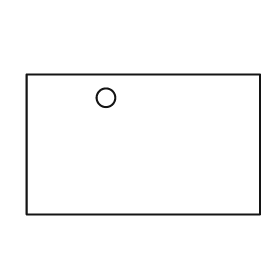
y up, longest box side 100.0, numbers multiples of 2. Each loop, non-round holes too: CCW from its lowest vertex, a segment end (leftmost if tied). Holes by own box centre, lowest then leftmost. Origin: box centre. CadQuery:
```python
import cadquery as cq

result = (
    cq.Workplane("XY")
    .moveTo(-50.0, -30.0)
    .lineTo(50.0, -30.0)
    .lineTo(50.0, 30.0)
    .lineTo(-50.0, 30.0)
    .close()
    .moveTo(-16.0, 20.0)
    .circle(4.0)
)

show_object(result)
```